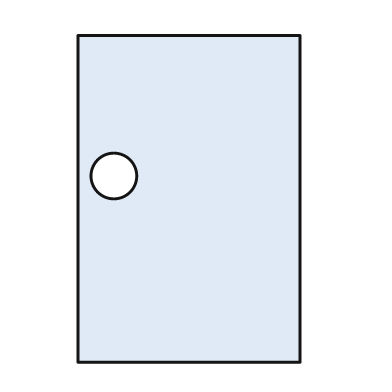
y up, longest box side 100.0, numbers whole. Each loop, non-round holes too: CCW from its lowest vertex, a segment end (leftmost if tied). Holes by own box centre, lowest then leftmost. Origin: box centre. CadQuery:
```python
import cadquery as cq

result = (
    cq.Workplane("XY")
    .moveTo(-34.0, -50.0)
    .lineTo(34.0, -50.0)
    .lineTo(34.0, 50.0)
    .lineTo(-34.0, 50.0)
    .close()
    .moveTo(-23.0, 7.0)
    .circle(7.0)
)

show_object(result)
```